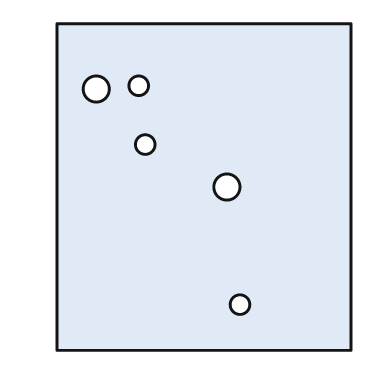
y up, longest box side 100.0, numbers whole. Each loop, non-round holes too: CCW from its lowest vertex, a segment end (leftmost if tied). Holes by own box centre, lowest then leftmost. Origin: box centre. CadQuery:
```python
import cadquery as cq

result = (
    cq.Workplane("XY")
    .moveTo(-45.0, -50.0)
    .lineTo(45.0, -50.0)
    .lineTo(45.0, 50.0)
    .lineTo(-45.0, 50.0)
    .close()
    .moveTo(11.0, -36.0)
    .circle(3.0)
    .moveTo(7.0, 0.0)
    .circle(4.0)
    .moveTo(-18.0, 13.0)
    .circle(3.0)
    .moveTo(-33.0, 30.0)
    .circle(4.0)
    .moveTo(-20.0, 31.0)
    .circle(3.0)
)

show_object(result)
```